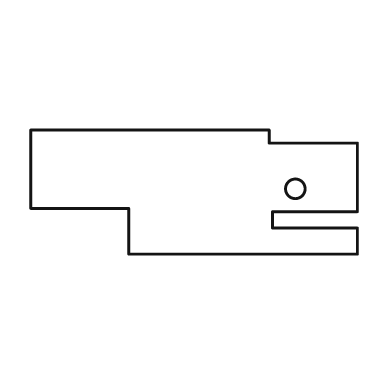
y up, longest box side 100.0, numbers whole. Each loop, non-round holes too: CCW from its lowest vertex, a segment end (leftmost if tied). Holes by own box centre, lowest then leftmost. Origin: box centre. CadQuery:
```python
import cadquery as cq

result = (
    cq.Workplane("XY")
    .moveTo(-20.0, -19.0)
    .lineTo(50.0, -19.0)
    .lineTo(50.0, -11.0)
    .lineTo(24.0, -11.0)
    .lineTo(24.0, -6.0)
    .lineTo(50.0, -6.0)
    .lineTo(50.0, 15.0)
    .lineTo(23.0, 15.0)
    .lineTo(23.0, 19.0)
    .lineTo(-50.0, 19.0)
    .lineTo(-50.0, -5.0)
    .lineTo(-20.0, -5.0)
    .close()
    .moveTo(31.0, 1.0)
    .circle(3.0)
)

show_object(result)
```